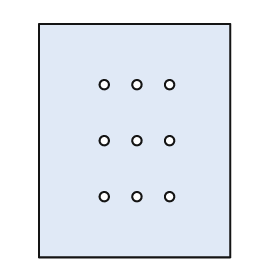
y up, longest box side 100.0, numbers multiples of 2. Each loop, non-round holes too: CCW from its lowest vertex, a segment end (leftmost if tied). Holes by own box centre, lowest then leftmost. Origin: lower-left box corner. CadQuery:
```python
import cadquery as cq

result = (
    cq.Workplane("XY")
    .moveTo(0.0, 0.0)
    .lineTo(82.0, 0.0)
    .lineTo(82.0, 100.0)
    .lineTo(0.0, 100.0)
    .close()
    .moveTo(28.0, 26.0)
    .circle(2.0)
    .moveTo(42.0, 26.0)
    .circle(2.0)
    .moveTo(56.0, 26.0)
    .circle(2.0)
    .moveTo(28.0, 50.0)
    .circle(2.0)
    .moveTo(42.0, 50.0)
    .circle(2.0)
    .moveTo(56.0, 50.0)
    .circle(2.0)
    .moveTo(28.0, 74.0)
    .circle(2.0)
    .moveTo(42.0, 74.0)
    .circle(2.0)
    .moveTo(56.0, 74.0)
    .circle(2.0)
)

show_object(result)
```